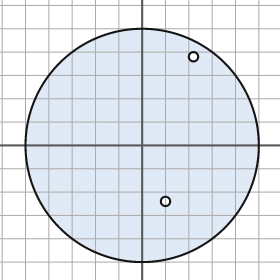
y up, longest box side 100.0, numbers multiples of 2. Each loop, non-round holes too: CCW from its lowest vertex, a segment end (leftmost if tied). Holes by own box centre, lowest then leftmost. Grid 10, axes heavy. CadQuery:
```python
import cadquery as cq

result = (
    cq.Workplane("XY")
    .moveTo(0.0, 0.0)
    .circle(50.0)
    .moveTo(10.0, -24.0)
    .circle(2.0)
    .moveTo(22.0, 38.0)
    .circle(2.0)
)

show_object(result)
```